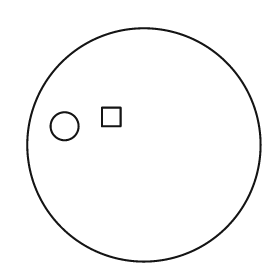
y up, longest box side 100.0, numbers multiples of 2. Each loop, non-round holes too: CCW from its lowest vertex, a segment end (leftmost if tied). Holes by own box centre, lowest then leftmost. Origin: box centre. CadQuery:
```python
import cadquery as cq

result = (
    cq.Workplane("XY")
    .moveTo(0.0, 0.0)
    .circle(50.0)
    .moveTo(-34.0, 8.0)
    .circle(6.0)
    .moveTo(-18.0, 8.0)
    .lineTo(-10.0, 8.0)
    .lineTo(-10.0, 16.0)
    .lineTo(-18.0, 16.0)
    .close()
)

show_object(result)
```